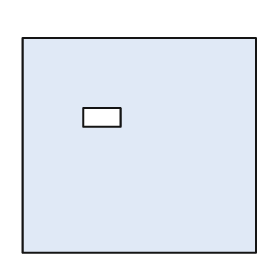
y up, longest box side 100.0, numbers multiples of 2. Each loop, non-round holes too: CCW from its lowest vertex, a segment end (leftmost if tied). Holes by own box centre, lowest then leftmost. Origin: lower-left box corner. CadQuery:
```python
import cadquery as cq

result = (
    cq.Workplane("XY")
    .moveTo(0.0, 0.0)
    .lineTo(100.0, 0.0)
    .lineTo(100.0, 92.0)
    .lineTo(0.0, 92.0)
    .close()
    .moveTo(26.0, 54.0)
    .lineTo(42.0, 54.0)
    .lineTo(42.0, 62.0)
    .lineTo(26.0, 62.0)
    .close()
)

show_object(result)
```